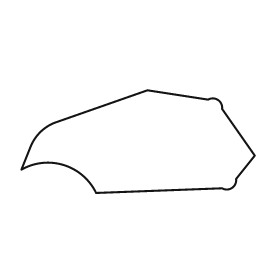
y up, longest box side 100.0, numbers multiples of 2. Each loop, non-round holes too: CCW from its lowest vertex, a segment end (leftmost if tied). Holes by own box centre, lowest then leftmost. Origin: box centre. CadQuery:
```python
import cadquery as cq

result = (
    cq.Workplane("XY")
    .moveTo(-18.0, -22.0)
    .lineTo(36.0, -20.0)
    .threePointArc((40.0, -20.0), (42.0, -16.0))
    .lineTo(50.0, -6.0)
    .lineTo(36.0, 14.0)
    .threePointArc((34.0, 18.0), (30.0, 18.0))
    .lineTo(4.0, 22.0)
    .lineTo(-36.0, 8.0)
    .threePointArc((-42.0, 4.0), (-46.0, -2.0))
    .lineTo(-50.0, -12.0)
    .threePointArc((-32.0, -10.0), (-18.0, -22.0))
    .close()
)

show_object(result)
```